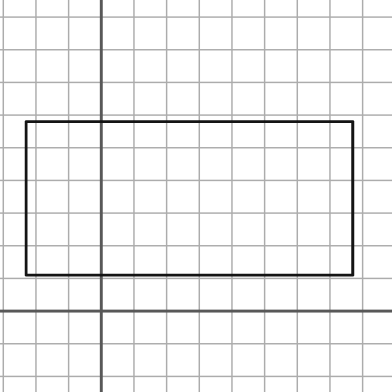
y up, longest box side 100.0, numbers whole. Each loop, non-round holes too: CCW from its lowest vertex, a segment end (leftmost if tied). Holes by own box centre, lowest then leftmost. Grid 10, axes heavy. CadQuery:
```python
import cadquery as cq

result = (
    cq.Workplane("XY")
    .moveTo(-23.0, 11.0)
    .lineTo(77.0, 11.0)
    .lineTo(77.0, 58.0)
    .lineTo(-23.0, 58.0)
    .close()
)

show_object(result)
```